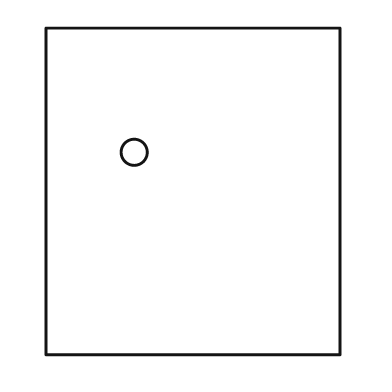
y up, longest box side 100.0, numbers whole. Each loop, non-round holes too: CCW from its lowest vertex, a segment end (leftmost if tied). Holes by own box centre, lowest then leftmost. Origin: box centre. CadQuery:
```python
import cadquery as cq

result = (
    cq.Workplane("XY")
    .moveTo(-45.0, -50.0)
    .lineTo(45.0, -50.0)
    .lineTo(45.0, 50.0)
    .lineTo(-45.0, 50.0)
    .close()
    .moveTo(-18.0, 12.0)
    .circle(4.0)
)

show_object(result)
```